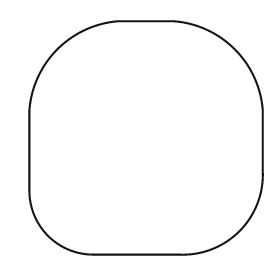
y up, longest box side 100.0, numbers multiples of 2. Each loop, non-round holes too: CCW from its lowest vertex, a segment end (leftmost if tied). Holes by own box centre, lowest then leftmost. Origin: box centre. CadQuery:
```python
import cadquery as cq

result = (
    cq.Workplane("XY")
    .moveTo(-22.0, -50.0)
    .lineTo(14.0, -50.0)
    .threePointArc((40.0, -40.0), (50.0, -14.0))
    .lineTo(50.0, 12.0)
    .threePointArc((38.0, 38.0), (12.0, 50.0))
    .lineTo(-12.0, 50.0)
    .threePointArc((-38.0, 38.0), (-50.0, 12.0))
    .lineTo(-50.0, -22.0)
    .threePointArc((-42.0, -42.0), (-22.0, -50.0))
    .close()
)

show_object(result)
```